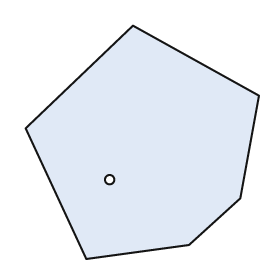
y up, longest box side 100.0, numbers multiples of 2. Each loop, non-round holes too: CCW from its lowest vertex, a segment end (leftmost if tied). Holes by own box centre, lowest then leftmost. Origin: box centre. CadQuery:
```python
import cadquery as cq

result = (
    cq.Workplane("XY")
    .moveTo(-24.0, -50.0)
    .lineTo(20.0, -44.0)
    .lineTo(42.0, -24.0)
    .lineTo(50.0, 20.0)
    .lineTo(-4.0, 50.0)
    .lineTo(-50.0, 6.0)
    .close()
    .moveTo(-14.0, -16.0)
    .circle(2.0)
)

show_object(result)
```